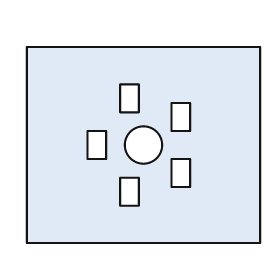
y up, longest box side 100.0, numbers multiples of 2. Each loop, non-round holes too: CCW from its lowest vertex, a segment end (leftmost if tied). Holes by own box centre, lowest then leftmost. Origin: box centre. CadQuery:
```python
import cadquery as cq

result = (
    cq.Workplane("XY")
    .moveTo(-50.0, -42.0)
    .lineTo(50.0, -42.0)
    .lineTo(50.0, 42.0)
    .lineTo(-50.0, 42.0)
    .close()
    .moveTo(-10.0, -26.0)
    .lineTo(-2.0, -26.0)
    .lineTo(-2.0, -14.0)
    .lineTo(-10.0, -14.0)
    .close()
    .moveTo(12.0, -18.0)
    .lineTo(20.0, -18.0)
    .lineTo(20.0, -6.0)
    .lineTo(12.0, -6.0)
    .close()
    .moveTo(-24.0, -6.0)
    .lineTo(-16.0, -6.0)
    .lineTo(-16.0, 6.0)
    .lineTo(-24.0, 6.0)
    .close()
    .moveTo(0.0, 0.0)
    .circle(8.0)
    .moveTo(12.0, 6.0)
    .lineTo(20.0, 6.0)
    .lineTo(20.0, 18.0)
    .lineTo(12.0, 18.0)
    .close()
    .moveTo(-10.0, 14.0)
    .lineTo(-2.0, 14.0)
    .lineTo(-2.0, 26.0)
    .lineTo(-10.0, 26.0)
    .close()
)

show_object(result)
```